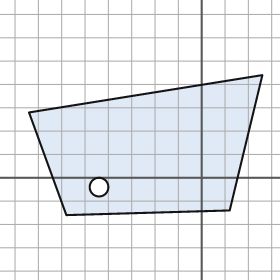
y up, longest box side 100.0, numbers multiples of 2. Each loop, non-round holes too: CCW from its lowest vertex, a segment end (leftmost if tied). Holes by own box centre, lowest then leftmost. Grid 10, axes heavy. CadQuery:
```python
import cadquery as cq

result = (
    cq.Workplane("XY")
    .moveTo(-58.0, -16.0)
    .lineTo(12.0, -14.0)
    .lineTo(26.0, 44.0)
    .lineTo(-74.0, 28.0)
    .close()
    .moveTo(-44.0, -4.0)
    .circle(4.0)
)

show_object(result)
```